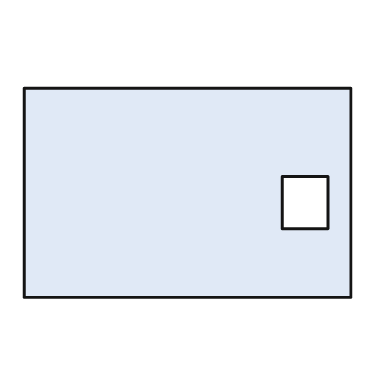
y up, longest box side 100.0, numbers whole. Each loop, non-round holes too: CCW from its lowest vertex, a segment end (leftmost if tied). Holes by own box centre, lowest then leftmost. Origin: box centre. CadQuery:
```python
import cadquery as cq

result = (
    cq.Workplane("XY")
    .moveTo(-50.0, -32.0)
    .lineTo(50.0, -32.0)
    .lineTo(50.0, 32.0)
    .lineTo(-50.0, 32.0)
    .close()
    .moveTo(29.0, -11.0)
    .lineTo(43.0, -11.0)
    .lineTo(43.0, 5.0)
    .lineTo(29.0, 5.0)
    .close()
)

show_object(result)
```